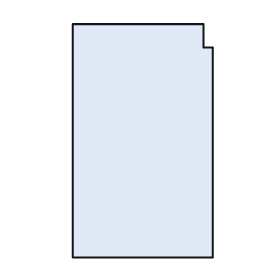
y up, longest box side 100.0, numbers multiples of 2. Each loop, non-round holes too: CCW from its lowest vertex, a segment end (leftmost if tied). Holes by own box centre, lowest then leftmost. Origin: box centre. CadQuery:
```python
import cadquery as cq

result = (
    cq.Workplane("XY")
    .moveTo(-30.0, -50.0)
    .lineTo(30.0, -50.0)
    .lineTo(30.0, 40.0)
    .lineTo(26.0, 40.0)
    .lineTo(26.0, 50.0)
    .lineTo(-30.0, 50.0)
    .close()
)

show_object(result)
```